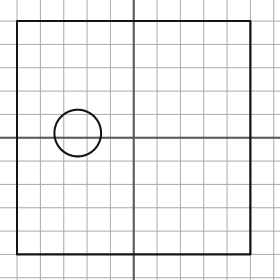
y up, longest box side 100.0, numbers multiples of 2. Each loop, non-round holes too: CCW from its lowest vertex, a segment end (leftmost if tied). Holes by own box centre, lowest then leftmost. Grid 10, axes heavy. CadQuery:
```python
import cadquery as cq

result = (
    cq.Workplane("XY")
    .moveTo(-50.0, -50.0)
    .lineTo(50.0, -50.0)
    .lineTo(50.0, 50.0)
    .lineTo(-50.0, 50.0)
    .close()
    .moveTo(-24.0, 2.0)
    .circle(10.0)
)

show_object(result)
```